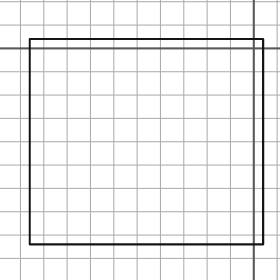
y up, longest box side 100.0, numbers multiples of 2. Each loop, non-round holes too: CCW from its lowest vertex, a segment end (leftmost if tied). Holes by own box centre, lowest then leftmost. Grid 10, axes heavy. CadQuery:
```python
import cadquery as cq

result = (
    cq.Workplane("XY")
    .moveTo(-96.0, -84.0)
    .lineTo(4.0, -84.0)
    .lineTo(4.0, 4.0)
    .lineTo(-96.0, 4.0)
    .close()
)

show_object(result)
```